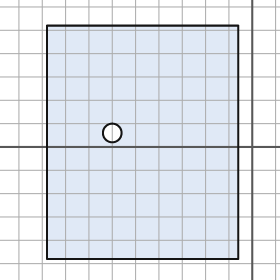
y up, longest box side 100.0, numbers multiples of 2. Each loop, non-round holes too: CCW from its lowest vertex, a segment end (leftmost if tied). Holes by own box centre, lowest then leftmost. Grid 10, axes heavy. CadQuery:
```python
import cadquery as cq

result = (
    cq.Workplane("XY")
    .moveTo(-88.0, -48.0)
    .lineTo(-6.0, -48.0)
    .lineTo(-6.0, 52.0)
    .lineTo(-88.0, 52.0)
    .close()
    .moveTo(-60.0, 6.0)
    .circle(4.0)
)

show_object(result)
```